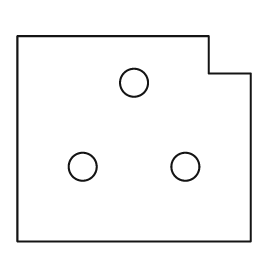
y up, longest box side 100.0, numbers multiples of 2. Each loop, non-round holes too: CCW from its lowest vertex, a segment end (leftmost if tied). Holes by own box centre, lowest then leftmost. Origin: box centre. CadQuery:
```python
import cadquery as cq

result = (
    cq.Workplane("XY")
    .moveTo(-50.0, -44.0)
    .lineTo(50.0, -44.0)
    .lineTo(50.0, 28.0)
    .lineTo(32.0, 28.0)
    .lineTo(32.0, 44.0)
    .lineTo(-50.0, 44.0)
    .close()
    .moveTo(-22.0, -12.0)
    .circle(6.0)
    .moveTo(22.0, -12.0)
    .circle(6.0)
    .moveTo(0.0, 24.0)
    .circle(6.0)
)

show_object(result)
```